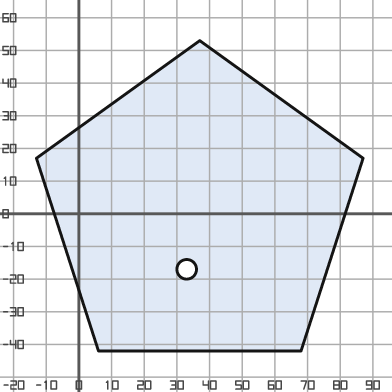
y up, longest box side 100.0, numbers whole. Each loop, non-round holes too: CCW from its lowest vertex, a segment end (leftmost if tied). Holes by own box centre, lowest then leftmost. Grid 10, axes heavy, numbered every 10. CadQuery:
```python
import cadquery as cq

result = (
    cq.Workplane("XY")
    .moveTo(6.0, -42.0)
    .lineTo(68.0, -42.0)
    .lineTo(87.0, 17.0)
    .lineTo(37.0, 53.0)
    .lineTo(-13.0, 17.0)
    .close()
    .moveTo(33.0, -17.0)
    .circle(3.0)
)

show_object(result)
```